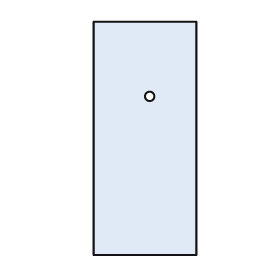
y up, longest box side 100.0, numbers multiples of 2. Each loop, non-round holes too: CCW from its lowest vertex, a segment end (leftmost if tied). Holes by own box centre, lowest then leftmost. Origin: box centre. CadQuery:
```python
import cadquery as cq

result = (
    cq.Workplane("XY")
    .moveTo(-22.0, -50.0)
    .lineTo(22.0, -50.0)
    .lineTo(22.0, 50.0)
    .lineTo(-22.0, 50.0)
    .close()
    .moveTo(2.0, 18.0)
    .circle(2.0)
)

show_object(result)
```